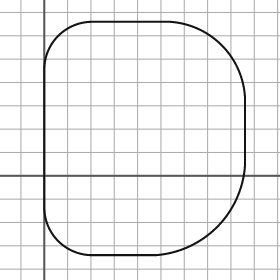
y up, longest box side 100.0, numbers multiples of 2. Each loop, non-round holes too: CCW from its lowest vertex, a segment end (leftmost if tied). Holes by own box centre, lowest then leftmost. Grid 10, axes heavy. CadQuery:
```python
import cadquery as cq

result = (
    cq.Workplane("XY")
    .moveTo(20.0, -34.0)
    .lineTo(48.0, -34.0)
    .threePointArc((74.0, -22.0), (86.0, 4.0))
    .lineTo(86.0, 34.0)
    .threePointArc((76.0, 56.0), (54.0, 66.0))
    .lineTo(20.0, 66.0)
    .threePointArc((6.0, 60.0), (0.0, 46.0))
    .lineTo(0.0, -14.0)
    .threePointArc((6.0, -28.0), (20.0, -34.0))
    .close()
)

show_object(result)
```